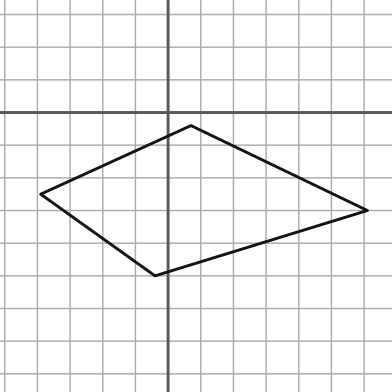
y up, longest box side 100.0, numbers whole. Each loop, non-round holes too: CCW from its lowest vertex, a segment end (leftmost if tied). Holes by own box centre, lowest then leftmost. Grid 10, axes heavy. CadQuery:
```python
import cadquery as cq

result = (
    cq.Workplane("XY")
    .moveTo(-4.0, -50.0)
    .lineTo(61.0, -30.0)
    .lineTo(7.0, -4.0)
    .lineTo(-39.0, -25.0)
    .close()
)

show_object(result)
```